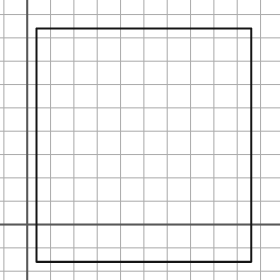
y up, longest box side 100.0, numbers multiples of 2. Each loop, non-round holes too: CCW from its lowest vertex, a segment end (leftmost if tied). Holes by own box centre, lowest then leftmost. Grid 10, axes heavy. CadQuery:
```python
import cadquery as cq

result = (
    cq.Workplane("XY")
    .moveTo(4.0, -16.0)
    .lineTo(96.0, -16.0)
    .lineTo(96.0, 84.0)
    .lineTo(4.0, 84.0)
    .close()
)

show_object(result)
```